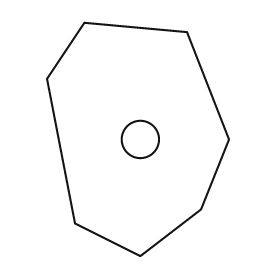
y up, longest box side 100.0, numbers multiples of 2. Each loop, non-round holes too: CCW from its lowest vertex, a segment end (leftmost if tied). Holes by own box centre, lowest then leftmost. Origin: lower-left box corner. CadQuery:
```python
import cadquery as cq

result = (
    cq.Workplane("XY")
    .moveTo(40.0, 0.0)
    .lineTo(66.0, 20.0)
    .lineTo(78.0, 50.0)
    .lineTo(60.0, 96.0)
    .lineTo(16.0, 100.0)
    .lineTo(0.0, 76.0)
    .lineTo(12.0, 14.0)
    .close()
    .moveTo(40.0, 50.0)
    .circle(8.0)
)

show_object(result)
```